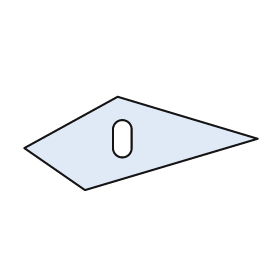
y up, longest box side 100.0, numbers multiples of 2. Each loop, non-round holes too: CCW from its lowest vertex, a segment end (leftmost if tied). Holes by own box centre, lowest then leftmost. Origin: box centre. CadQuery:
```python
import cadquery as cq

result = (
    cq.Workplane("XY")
    .moveTo(-24.0, -20.0)
    .lineTo(50.0, 2.0)
    .lineTo(-10.0, 20.0)
    .lineTo(-50.0, -2.0)
    .close()
    .moveTo(-12.0, -2.0)
    .threePointArc((-8.0, -6.0), (-4.0, -2.0))
    .lineTo(-4.0, 6.0)
    .threePointArc((-8.0, 10.0), (-12.0, 6.0))
    .close()
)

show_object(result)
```